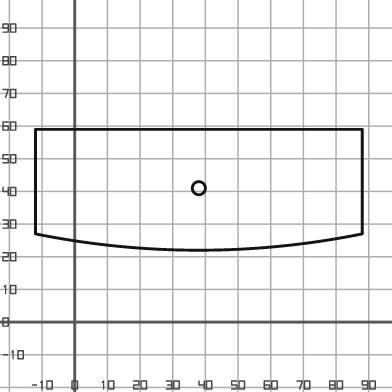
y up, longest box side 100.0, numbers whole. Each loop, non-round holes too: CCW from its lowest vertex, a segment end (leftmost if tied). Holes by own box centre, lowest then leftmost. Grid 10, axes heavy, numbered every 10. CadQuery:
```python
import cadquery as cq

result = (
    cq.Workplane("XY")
    .moveTo(-12.0, 27.0)
    .threePointArc((38.0, 22.0), (88.0, 27.0))
    .lineTo(88.0, 59.0)
    .lineTo(-12.0, 59.0)
    .close()
    .moveTo(38.0, 41.0)
    .circle(2.0)
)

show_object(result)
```